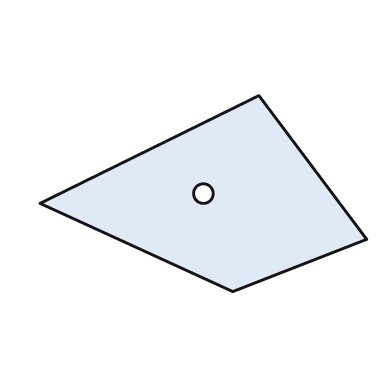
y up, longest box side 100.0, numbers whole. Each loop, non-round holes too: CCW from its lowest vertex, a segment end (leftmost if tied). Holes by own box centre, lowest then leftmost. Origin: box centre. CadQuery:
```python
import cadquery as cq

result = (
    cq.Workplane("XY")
    .moveTo(9.0, -30.0)
    .lineTo(50.0, -14.0)
    .lineTo(17.0, 30.0)
    .lineTo(-50.0, -3.0)
    .close()
    .moveTo(0.0, 0.0)
    .circle(3.0)
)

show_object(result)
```